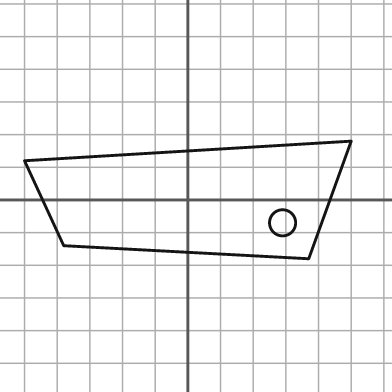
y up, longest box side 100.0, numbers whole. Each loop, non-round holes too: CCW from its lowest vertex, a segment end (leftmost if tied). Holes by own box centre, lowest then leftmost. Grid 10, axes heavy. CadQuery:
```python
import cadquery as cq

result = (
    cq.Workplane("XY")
    .moveTo(37.0, -18.0)
    .lineTo(50.0, 18.0)
    .lineTo(-50.0, 12.0)
    .lineTo(-38.0, -14.0)
    .close()
    .moveTo(29.0, -7.0)
    .circle(4.0)
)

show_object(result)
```